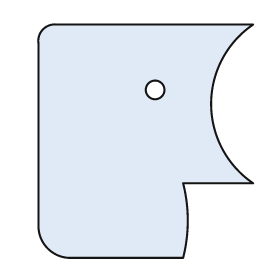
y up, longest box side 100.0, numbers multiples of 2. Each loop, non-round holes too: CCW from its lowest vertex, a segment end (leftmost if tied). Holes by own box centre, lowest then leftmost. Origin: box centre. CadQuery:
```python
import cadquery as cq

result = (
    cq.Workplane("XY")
    .moveTo(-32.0, -50.0)
    .lineTo(16.0, -50.0)
    .threePointArc((18.0, -34.0), (16.0, -18.0))
    .lineTo(46.0, -18.0)
    .threePointArc((28.0, 16.0), (46.0, 50.0))
    .lineTo(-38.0, 50.0)
    .threePointArc((-44.0, 48.0), (-46.0, 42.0))
    .lineTo(-46.0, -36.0)
    .threePointArc((-42.0, -46.0), (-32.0, -50.0))
    .close()
    .moveTo(4.0, 22.0)
    .circle(4.0)
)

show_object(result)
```